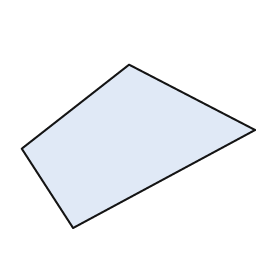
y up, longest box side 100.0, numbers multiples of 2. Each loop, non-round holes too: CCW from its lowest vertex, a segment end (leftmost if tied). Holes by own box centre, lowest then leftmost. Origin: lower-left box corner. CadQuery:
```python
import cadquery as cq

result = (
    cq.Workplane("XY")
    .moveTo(22.0, 0.0)
    .lineTo(100.0, 42.0)
    .lineTo(46.0, 70.0)
    .lineTo(0.0, 34.0)
    .close()
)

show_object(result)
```